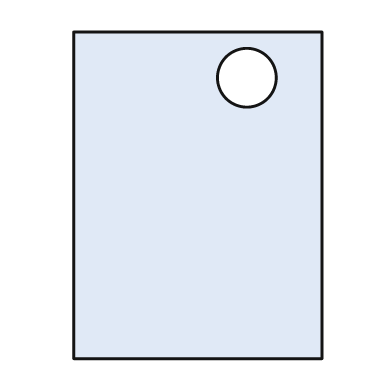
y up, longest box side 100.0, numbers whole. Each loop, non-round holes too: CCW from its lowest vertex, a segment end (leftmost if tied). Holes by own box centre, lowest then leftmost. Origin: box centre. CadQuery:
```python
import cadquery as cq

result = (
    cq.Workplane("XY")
    .moveTo(-38.0, -50.0)
    .lineTo(38.0, -50.0)
    .lineTo(38.0, 50.0)
    .lineTo(-38.0, 50.0)
    .close()
    .moveTo(15.0, 36.0)
    .circle(9.0)
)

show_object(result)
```